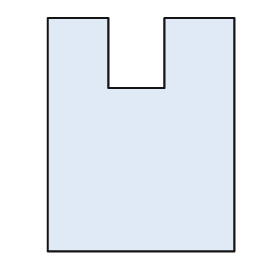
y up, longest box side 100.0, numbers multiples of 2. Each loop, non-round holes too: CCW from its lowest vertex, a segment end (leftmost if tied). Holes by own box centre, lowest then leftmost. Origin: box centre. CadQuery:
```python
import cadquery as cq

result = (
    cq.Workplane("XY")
    .moveTo(-40.0, -50.0)
    .lineTo(40.0, -50.0)
    .lineTo(40.0, 50.0)
    .lineTo(10.0, 50.0)
    .lineTo(10.0, 20.0)
    .lineTo(-14.0, 20.0)
    .lineTo(-14.0, 50.0)
    .lineTo(-40.0, 50.0)
    .close()
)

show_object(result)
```